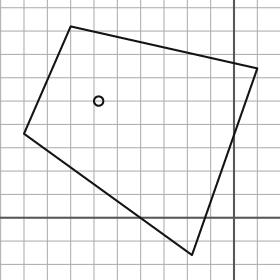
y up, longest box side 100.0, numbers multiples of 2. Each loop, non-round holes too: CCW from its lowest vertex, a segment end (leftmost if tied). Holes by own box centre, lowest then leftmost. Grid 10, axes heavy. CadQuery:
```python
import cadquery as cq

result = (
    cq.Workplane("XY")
    .moveTo(-18.0, -16.0)
    .lineTo(10.0, 64.0)
    .lineTo(-70.0, 82.0)
    .lineTo(-90.0, 36.0)
    .close()
    .moveTo(-58.0, 50.0)
    .circle(2.0)
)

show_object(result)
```